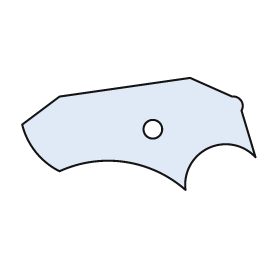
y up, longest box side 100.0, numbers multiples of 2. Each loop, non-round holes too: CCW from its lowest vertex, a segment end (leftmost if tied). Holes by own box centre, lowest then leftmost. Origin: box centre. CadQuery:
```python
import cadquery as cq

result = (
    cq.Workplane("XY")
    .moveTo(20.0, -24.0)
    .threePointArc((30.0, -6.0), (50.0, -10.0))
    .lineTo(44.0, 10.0)
    .threePointArc((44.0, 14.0), (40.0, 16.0))
    .lineTo(22.0, 24.0)
    .lineTo(-34.0, 16.0)
    .lineTo(-50.0, 4.0)
    .threePointArc((-44.0, -8.0), (-34.0, -16.0))
    .threePointArc((-6.0, -12.0), (20.0, -24.0))
    .close()
    .moveTo(6.0, 2.0)
    .circle(4.0)
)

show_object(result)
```